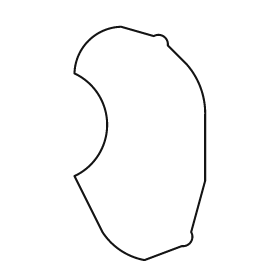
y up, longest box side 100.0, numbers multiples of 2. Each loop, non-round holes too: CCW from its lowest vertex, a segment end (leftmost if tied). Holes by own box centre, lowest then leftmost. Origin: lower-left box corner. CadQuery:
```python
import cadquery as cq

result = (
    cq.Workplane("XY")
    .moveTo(30.0, 0.0)
    .lineTo(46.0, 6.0)
    .threePointArc((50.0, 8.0), (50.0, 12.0))
    .lineTo(56.0, 34.0)
    .lineTo(56.0, 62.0)
    .threePointArc((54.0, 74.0), (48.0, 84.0))
    .lineTo(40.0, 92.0)
    .threePointArc((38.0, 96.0), (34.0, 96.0))
    .lineTo(20.0, 100.0)
    .threePointArc((6.0, 94.0), (0.0, 80.0))
    .threePointArc((14.0, 58.0), (0.0, 36.0))
    .lineTo(12.0, 12.0)
    .threePointArc((20.0, 4.0), (30.0, 0.0))
    .close()
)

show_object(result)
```